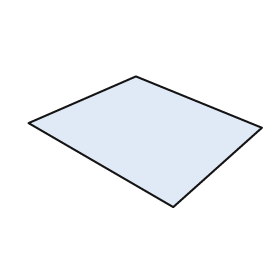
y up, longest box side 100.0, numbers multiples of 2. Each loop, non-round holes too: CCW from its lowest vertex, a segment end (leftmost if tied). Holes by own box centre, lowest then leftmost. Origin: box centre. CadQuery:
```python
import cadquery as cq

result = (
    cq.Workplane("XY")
    .moveTo(12.0, -28.0)
    .lineTo(50.0, 6.0)
    .lineTo(-4.0, 28.0)
    .lineTo(-50.0, 8.0)
    .close()
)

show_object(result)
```